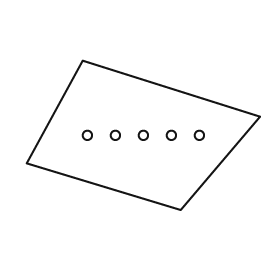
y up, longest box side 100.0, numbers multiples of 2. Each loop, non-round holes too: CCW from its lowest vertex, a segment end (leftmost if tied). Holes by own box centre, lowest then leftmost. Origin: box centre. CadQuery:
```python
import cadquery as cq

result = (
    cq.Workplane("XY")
    .moveTo(16.0, -32.0)
    .lineTo(50.0, 8.0)
    .lineTo(-26.0, 32.0)
    .lineTo(-50.0, -12.0)
    .close()
    .moveTo(-24.0, 0.0)
    .circle(2.0)
    .moveTo(-12.0, 0.0)
    .circle(2.0)
    .moveTo(0.0, 0.0)
    .circle(2.0)
    .moveTo(12.0, 0.0)
    .circle(2.0)
    .moveTo(24.0, 0.0)
    .circle(2.0)
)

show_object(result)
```